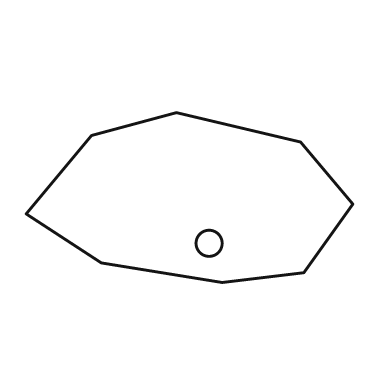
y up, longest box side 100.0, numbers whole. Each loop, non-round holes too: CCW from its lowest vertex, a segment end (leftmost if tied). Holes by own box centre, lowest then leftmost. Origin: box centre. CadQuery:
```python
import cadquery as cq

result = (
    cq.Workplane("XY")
    .moveTo(10.0, -26.0)
    .lineTo(35.0, -23.0)
    .lineTo(50.0, -2.0)
    .lineTo(34.0, 17.0)
    .lineTo(-4.0, 26.0)
    .lineTo(-30.0, 19.0)
    .lineTo(-50.0, -5.0)
    .lineTo(-27.0, -20.0)
    .close()
    .moveTo(6.0, -14.0)
    .circle(4.0)
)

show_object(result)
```